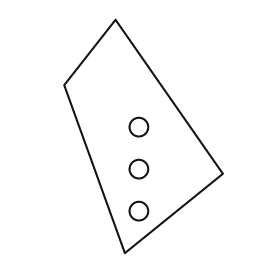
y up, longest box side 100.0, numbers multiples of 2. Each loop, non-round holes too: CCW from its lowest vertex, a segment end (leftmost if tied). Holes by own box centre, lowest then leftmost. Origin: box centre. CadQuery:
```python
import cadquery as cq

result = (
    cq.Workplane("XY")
    .moveTo(-8.0, -50.0)
    .lineTo(34.0, -16.0)
    .lineTo(-12.0, 50.0)
    .lineTo(-34.0, 22.0)
    .close()
    .moveTo(-2.0, -32.0)
    .circle(4.0)
    .moveTo(-2.0, -14.0)
    .circle(4.0)
    .moveTo(-2.0, 4.0)
    .circle(4.0)
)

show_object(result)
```